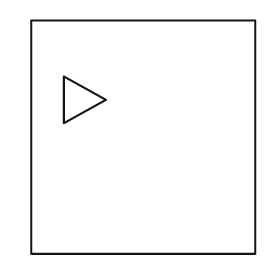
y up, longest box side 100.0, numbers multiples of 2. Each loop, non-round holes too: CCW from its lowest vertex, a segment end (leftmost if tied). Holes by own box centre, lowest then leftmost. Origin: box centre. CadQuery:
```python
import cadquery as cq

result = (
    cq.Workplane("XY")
    .moveTo(-48.0, -50.0)
    .lineTo(48.0, -50.0)
    .lineTo(48.0, 50.0)
    .lineTo(-48.0, 50.0)
    .close()
    .moveTo(-34.0, 6.0)
    .lineTo(-16.0, 16.0)
    .lineTo(-34.0, 26.0)
    .close()
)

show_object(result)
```